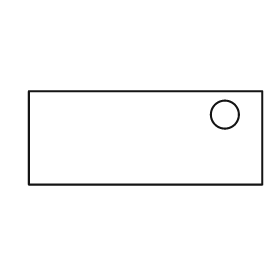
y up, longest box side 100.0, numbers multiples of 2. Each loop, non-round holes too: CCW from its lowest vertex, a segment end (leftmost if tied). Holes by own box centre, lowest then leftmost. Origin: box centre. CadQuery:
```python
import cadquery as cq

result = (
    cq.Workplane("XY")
    .moveTo(-50.0, -20.0)
    .lineTo(50.0, -20.0)
    .lineTo(50.0, 20.0)
    .lineTo(-50.0, 20.0)
    .close()
    .moveTo(34.0, 10.0)
    .circle(6.0)
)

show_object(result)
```